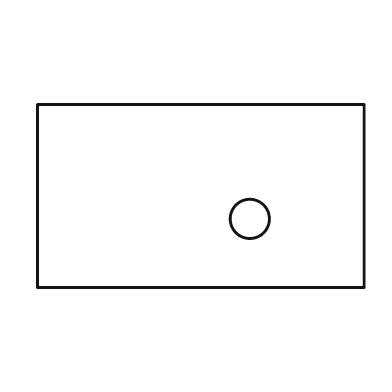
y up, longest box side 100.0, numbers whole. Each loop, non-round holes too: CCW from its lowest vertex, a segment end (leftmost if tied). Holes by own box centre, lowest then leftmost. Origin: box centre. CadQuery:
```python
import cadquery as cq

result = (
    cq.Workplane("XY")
    .moveTo(-50.0, -28.0)
    .lineTo(50.0, -28.0)
    .lineTo(50.0, 28.0)
    .lineTo(-50.0, 28.0)
    .close()
    .moveTo(15.0, -7.0)
    .circle(6.0)
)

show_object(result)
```